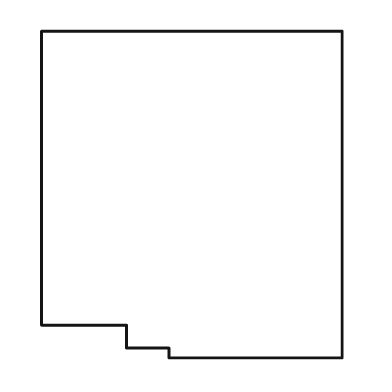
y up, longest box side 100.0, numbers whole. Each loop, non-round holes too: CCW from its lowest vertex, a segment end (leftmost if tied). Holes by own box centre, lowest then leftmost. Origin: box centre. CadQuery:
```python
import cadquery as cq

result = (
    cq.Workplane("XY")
    .moveTo(-7.0, -50.0)
    .lineTo(46.0, -50.0)
    .lineTo(46.0, 50.0)
    .lineTo(-46.0, 50.0)
    .lineTo(-46.0, -40.0)
    .lineTo(-20.0, -40.0)
    .lineTo(-20.0, -47.0)
    .lineTo(-7.0, -47.0)
    .close()
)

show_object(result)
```